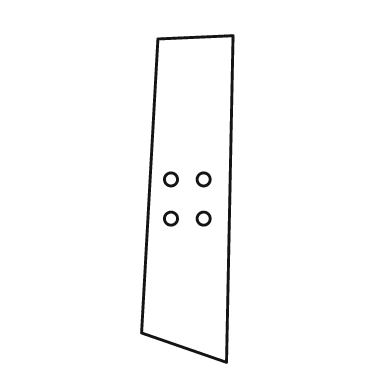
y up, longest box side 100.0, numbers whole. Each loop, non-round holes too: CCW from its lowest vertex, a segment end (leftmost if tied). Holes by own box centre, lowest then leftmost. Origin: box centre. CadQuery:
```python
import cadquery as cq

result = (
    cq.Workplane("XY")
    .moveTo(12.0, -50.0)
    .lineTo(14.0, 50.0)
    .lineTo(-9.0, 49.0)
    .lineTo(-14.0, -41.0)
    .close()
    .moveTo(-5.0, -6.0)
    .circle(2.0)
    .moveTo(5.0, -6.0)
    .circle(2.0)
    .moveTo(-5.0, 6.0)
    .circle(2.0)
    .moveTo(5.0, 6.0)
    .circle(2.0)
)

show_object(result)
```